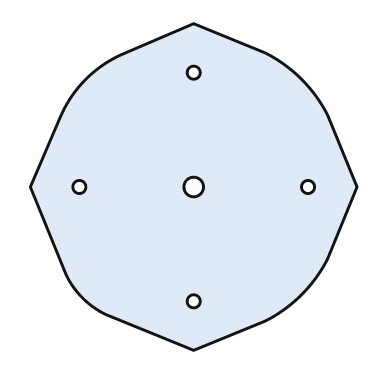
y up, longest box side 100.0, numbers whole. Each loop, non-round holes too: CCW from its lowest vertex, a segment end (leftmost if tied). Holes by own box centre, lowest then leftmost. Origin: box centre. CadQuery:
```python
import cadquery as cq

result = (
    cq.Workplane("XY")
    .moveTo(0.0, -50.0)
    .lineTo(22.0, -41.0)
    .threePointArc((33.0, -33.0), (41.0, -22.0))
    .lineTo(50.0, 0.0)
    .lineTo(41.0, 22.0)
    .threePointArc((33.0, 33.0), (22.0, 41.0))
    .lineTo(0.0, 50.0)
    .lineTo(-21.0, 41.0)
    .threePointArc((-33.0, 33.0), (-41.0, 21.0))
    .lineTo(-50.0, 0.0)
    .lineTo(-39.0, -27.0)
    .threePointArc((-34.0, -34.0), (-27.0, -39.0))
    .close()
    .moveTo(0.0, -35.0)
    .circle(2.0)
    .moveTo(-35.0, 0.0)
    .circle(2.0)
    .moveTo(0.0, 0.0)
    .circle(3.0)
    .moveTo(35.0, 0.0)
    .circle(2.0)
    .moveTo(0.0, 35.0)
    .circle(2.0)
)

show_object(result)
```